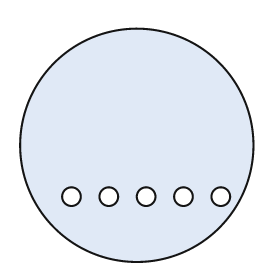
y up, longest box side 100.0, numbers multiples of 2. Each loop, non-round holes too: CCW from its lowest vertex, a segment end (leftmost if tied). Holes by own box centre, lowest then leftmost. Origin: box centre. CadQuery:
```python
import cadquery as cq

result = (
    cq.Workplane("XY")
    .moveTo(0.0, 0.0)
    .circle(50.0)
    .moveTo(-28.0, -22.0)
    .circle(4.0)
    .moveTo(-12.0, -22.0)
    .circle(4.0)
    .moveTo(4.0, -22.0)
    .circle(4.0)
    .moveTo(20.0, -22.0)
    .circle(4.0)
    .moveTo(36.0, -22.0)
    .circle(4.0)
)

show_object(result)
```